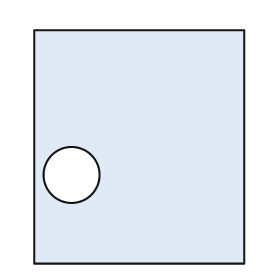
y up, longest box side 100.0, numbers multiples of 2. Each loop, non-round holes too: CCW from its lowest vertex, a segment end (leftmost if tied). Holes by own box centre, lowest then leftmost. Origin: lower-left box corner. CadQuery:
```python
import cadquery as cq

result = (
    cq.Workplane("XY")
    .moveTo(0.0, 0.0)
    .lineTo(90.0, 0.0)
    .lineTo(90.0, 100.0)
    .lineTo(0.0, 100.0)
    .close()
    .moveTo(16.0, 38.0)
    .circle(12.0)
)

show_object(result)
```